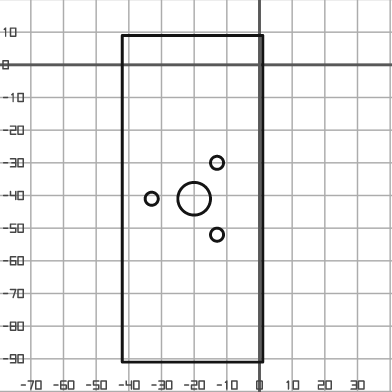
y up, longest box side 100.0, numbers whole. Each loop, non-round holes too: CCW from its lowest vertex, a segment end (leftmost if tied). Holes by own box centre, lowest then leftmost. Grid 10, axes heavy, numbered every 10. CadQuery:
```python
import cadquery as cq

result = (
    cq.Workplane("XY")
    .moveTo(-42.0, -91.0)
    .lineTo(1.0, -91.0)
    .lineTo(1.0, 9.0)
    .lineTo(-42.0, 9.0)
    .close()
    .moveTo(-13.0, -52.0)
    .circle(2.0)
    .moveTo(-33.0, -41.0)
    .circle(2.0)
    .moveTo(-20.0, -41.0)
    .circle(5.0)
    .moveTo(-13.0, -30.0)
    .circle(2.0)
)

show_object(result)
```